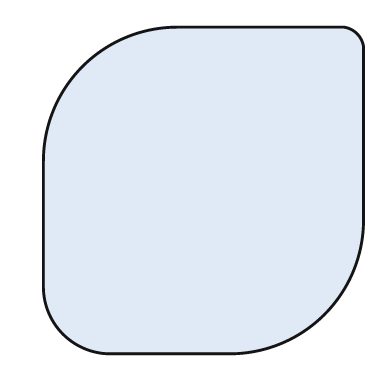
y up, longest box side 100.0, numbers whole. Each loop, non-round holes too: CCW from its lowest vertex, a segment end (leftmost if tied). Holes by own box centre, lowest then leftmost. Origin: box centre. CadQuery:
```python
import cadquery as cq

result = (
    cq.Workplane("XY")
    .moveTo(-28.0, -50.0)
    .lineTo(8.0, -50.0)
    .threePointArc((37.0, -38.0), (49.0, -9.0))
    .lineTo(49.0, 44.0)
    .threePointArc((47.0, 48.0), (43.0, 50.0))
    .lineTo(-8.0, 50.0)
    .threePointArc((-37.0, 38.0), (-49.0, 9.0))
    .lineTo(-49.0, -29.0)
    .threePointArc((-43.0, -44.0), (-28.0, -50.0))
    .close()
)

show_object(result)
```